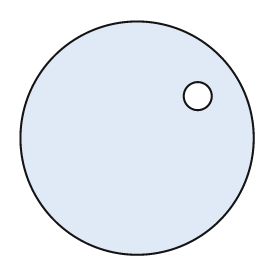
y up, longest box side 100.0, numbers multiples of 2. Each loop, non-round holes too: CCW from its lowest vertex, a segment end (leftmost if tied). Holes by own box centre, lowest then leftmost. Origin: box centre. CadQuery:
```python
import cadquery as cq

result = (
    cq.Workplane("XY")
    .moveTo(0.0, 0.0)
    .circle(50.0)
    .moveTo(26.0, 18.0)
    .circle(6.0)
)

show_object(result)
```